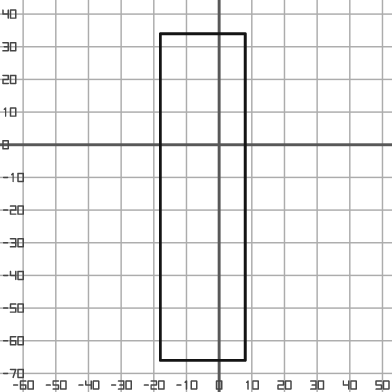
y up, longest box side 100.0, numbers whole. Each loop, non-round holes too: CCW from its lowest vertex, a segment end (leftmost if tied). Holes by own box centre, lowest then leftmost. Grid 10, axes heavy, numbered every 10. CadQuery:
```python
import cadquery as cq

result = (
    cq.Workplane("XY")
    .moveTo(-18.0, -66.0)
    .lineTo(8.0, -66.0)
    .lineTo(8.0, 34.0)
    .lineTo(-18.0, 34.0)
    .close()
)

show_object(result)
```